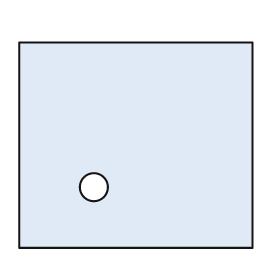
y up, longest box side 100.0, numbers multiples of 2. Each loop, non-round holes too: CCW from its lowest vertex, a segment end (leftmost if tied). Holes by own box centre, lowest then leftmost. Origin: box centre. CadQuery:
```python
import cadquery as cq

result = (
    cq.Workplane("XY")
    .moveTo(-50.0, -44.0)
    .lineTo(50.0, -44.0)
    .lineTo(50.0, 44.0)
    .lineTo(-50.0, 44.0)
    .close()
    .moveTo(-18.0, -18.0)
    .circle(6.0)
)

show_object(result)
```